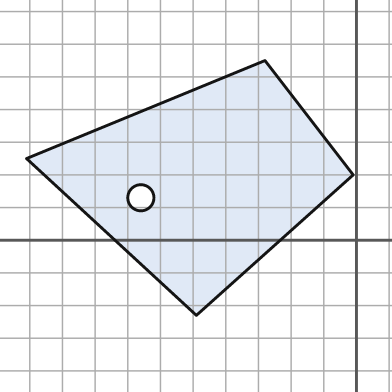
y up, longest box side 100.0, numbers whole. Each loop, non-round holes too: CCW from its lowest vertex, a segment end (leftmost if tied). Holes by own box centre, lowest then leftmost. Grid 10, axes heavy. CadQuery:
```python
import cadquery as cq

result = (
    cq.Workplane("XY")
    .moveTo(-49.0, -23.0)
    .lineTo(-1.0, 20.0)
    .lineTo(-28.0, 55.0)
    .lineTo(-101.0, 25.0)
    .close()
    .moveTo(-66.0, 13.0)
    .circle(4.0)
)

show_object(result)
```